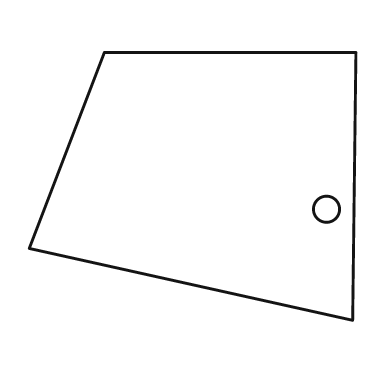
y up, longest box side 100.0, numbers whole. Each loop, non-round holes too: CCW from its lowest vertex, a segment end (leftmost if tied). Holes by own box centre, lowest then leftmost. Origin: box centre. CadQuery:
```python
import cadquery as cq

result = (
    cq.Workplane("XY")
    .moveTo(49.0, -41.0)
    .lineTo(50.0, 41.0)
    .lineTo(-27.0, 41.0)
    .lineTo(-50.0, -19.0)
    .close()
    .moveTo(41.0, -7.0)
    .circle(4.0)
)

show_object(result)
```